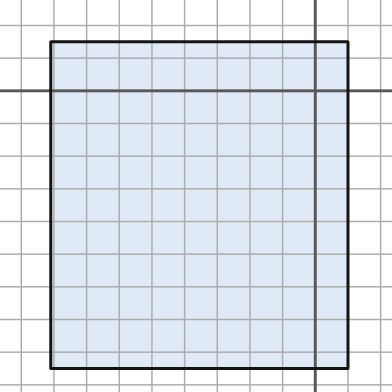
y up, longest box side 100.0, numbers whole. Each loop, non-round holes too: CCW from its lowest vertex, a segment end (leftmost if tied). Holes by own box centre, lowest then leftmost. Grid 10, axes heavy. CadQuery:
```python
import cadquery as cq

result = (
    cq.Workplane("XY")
    .moveTo(-81.0, -85.0)
    .lineTo(10.0, -85.0)
    .lineTo(10.0, 15.0)
    .lineTo(-81.0, 15.0)
    .close()
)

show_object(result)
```